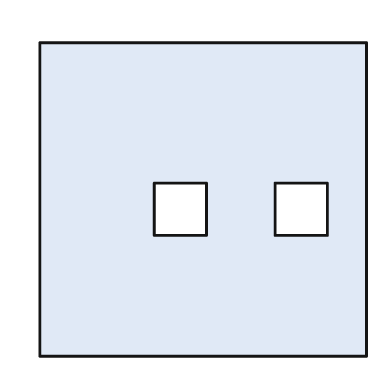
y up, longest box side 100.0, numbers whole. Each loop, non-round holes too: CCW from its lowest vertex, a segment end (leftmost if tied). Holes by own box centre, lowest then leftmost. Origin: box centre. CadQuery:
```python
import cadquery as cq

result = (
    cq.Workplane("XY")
    .moveTo(-50.0, -48.0)
    .lineTo(50.0, -48.0)
    .lineTo(50.0, 48.0)
    .lineTo(-50.0, 48.0)
    .close()
    .moveTo(-15.0, -11.0)
    .lineTo(1.0, -11.0)
    .lineTo(1.0, 5.0)
    .lineTo(-15.0, 5.0)
    .close()
    .moveTo(22.0, -11.0)
    .lineTo(38.0, -11.0)
    .lineTo(38.0, 5.0)
    .lineTo(22.0, 5.0)
    .close()
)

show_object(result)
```